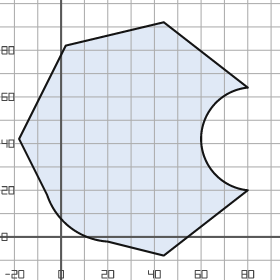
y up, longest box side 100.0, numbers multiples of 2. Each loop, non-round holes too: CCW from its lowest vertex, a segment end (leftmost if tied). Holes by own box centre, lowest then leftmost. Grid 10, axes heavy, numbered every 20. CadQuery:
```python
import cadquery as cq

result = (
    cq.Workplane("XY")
    .moveTo(44.0, -8.0)
    .lineTo(80.0, 20.0)
    .threePointArc((60.0, 42.0), (80.0, 64.0))
    .lineTo(44.0, 92.0)
    .lineTo(2.0, 82.0)
    .lineTo(-18.0, 42.0)
    .lineTo(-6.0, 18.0)
    .threePointArc((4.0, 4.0), (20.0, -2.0))
    .close()
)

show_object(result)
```